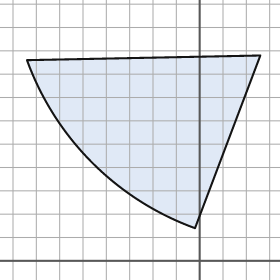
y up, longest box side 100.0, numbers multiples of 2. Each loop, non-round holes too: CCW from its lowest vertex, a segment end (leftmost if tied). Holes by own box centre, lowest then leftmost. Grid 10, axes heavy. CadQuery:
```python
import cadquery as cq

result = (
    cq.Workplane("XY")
    .moveTo(-2.0, 14.0)
    .lineTo(26.0, 88.0)
    .lineTo(-74.0, 86.0)
    .threePointArc((-46.0, 42.0), (-2.0, 14.0))
    .close()
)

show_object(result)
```